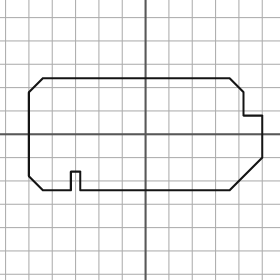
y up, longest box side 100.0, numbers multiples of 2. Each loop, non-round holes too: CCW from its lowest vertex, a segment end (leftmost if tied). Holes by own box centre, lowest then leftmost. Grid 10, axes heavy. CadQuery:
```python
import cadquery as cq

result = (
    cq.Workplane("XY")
    .moveTo(-44.0, -24.0)
    .lineTo(-32.0, -24.0)
    .lineTo(-32.0, -16.0)
    .lineTo(-28.0, -16.0)
    .lineTo(-28.0, -24.0)
    .lineTo(36.0, -24.0)
    .lineTo(50.0, -10.0)
    .lineTo(50.0, 8.0)
    .lineTo(42.0, 8.0)
    .lineTo(42.0, 18.0)
    .lineTo(36.0, 24.0)
    .lineTo(-44.0, 24.0)
    .lineTo(-50.0, 18.0)
    .lineTo(-50.0, -18.0)
    .close()
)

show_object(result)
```